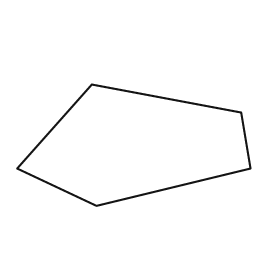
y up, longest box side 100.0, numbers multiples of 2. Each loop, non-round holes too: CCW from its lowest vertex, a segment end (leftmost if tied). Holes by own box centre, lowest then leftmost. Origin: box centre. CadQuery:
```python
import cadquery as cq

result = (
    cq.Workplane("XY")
    .moveTo(-16.0, -26.0)
    .lineTo(50.0, -10.0)
    .lineTo(46.0, 14.0)
    .lineTo(-18.0, 26.0)
    .lineTo(-50.0, -10.0)
    .close()
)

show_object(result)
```